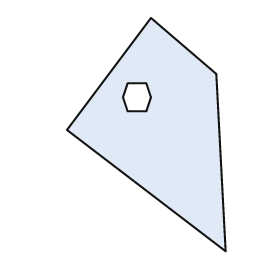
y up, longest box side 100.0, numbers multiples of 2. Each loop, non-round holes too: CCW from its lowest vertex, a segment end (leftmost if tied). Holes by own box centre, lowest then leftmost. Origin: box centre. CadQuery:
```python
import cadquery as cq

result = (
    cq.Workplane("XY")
    .moveTo(34.0, -50.0)
    .lineTo(30.0, 26.0)
    .lineTo(2.0, 50.0)
    .lineTo(-34.0, 2.0)
    .close()
    .moveTo(-8.0, 10.0)
    .lineTo(0.0, 10.0)
    .lineTo(2.0, 16.0)
    .lineTo(0.0, 22.0)
    .lineTo(-8.0, 22.0)
    .lineTo(-10.0, 16.0)
    .close()
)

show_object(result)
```